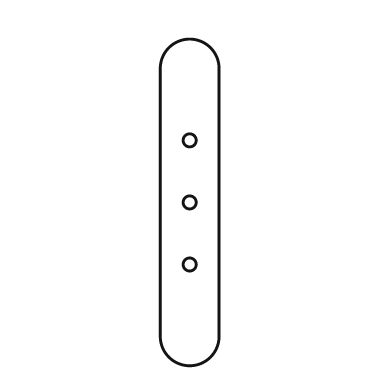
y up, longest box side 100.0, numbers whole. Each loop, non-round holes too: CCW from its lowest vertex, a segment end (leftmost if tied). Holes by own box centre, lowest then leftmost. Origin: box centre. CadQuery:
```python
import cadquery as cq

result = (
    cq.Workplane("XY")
    .moveTo(-9.0, -41.0)
    .threePointArc((0.0, -50.0), (9.0, -41.0))
    .lineTo(9.0, 41.0)
    .threePointArc((0.0, 50.0), (-9.0, 41.0))
    .close()
    .moveTo(0.0, -19.0)
    .circle(2.0)
    .moveTo(0.0, 0.0)
    .circle(2.0)
    .moveTo(0.0, 19.0)
    .circle(2.0)
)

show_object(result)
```